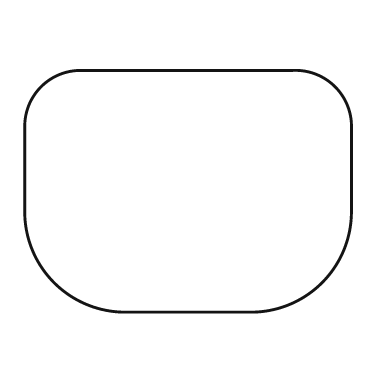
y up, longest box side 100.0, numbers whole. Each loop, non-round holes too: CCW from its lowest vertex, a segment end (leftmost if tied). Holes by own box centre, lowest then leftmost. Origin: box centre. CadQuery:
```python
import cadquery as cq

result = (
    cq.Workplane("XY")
    .moveTo(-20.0, -37.0)
    .lineTo(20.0, -37.0)
    .threePointArc((41.0, -28.0), (50.0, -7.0))
    .lineTo(50.0, 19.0)
    .threePointArc((45.0, 32.0), (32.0, 37.0))
    .lineTo(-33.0, 37.0)
    .threePointArc((-45.0, 32.0), (-50.0, 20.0))
    .lineTo(-50.0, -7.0)
    .threePointArc((-41.0, -28.0), (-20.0, -37.0))
    .close()
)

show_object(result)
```